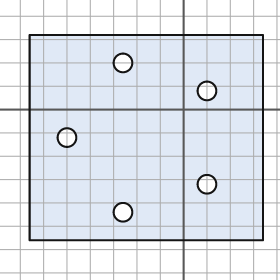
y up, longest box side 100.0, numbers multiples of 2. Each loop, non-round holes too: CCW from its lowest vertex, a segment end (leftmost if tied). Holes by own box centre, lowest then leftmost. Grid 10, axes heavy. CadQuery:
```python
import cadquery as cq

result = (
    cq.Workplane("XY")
    .moveTo(-66.0, -56.0)
    .lineTo(34.0, -56.0)
    .lineTo(34.0, 32.0)
    .lineTo(-66.0, 32.0)
    .close()
    .moveTo(-26.0, -44.0)
    .circle(4.0)
    .moveTo(10.0, -32.0)
    .circle(4.0)
    .moveTo(-50.0, -12.0)
    .circle(4.0)
    .moveTo(10.0, 8.0)
    .circle(4.0)
    .moveTo(-26.0, 20.0)
    .circle(4.0)
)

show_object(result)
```